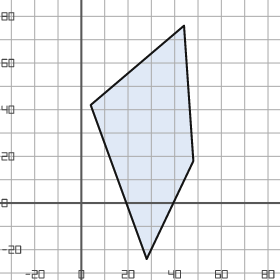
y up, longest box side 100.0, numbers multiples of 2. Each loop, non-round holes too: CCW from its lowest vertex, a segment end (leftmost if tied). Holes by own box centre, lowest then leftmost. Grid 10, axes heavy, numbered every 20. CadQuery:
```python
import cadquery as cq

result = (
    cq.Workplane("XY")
    .moveTo(28.0, -24.0)
    .lineTo(48.0, 18.0)
    .lineTo(44.0, 76.0)
    .lineTo(4.0, 42.0)
    .close()
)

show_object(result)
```